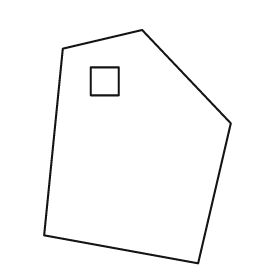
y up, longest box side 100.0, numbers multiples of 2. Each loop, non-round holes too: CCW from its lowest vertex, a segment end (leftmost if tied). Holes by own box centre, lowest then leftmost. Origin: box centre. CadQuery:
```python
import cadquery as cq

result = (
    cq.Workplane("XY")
    .moveTo(26.0, -50.0)
    .lineTo(40.0, 10.0)
    .lineTo(2.0, 50.0)
    .lineTo(-32.0, 42.0)
    .lineTo(-40.0, -38.0)
    .close()
    .moveTo(-20.0, 22.0)
    .lineTo(-8.0, 22.0)
    .lineTo(-8.0, 34.0)
    .lineTo(-20.0, 34.0)
    .close()
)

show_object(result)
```